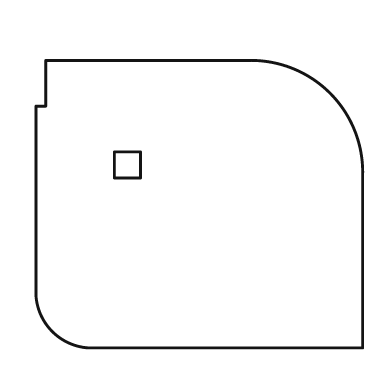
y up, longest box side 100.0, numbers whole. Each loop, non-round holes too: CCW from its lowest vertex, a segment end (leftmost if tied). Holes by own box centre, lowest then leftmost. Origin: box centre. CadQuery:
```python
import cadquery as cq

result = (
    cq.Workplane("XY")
    .moveTo(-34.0, -44.0)
    .lineTo(50.0, -44.0)
    .lineTo(50.0, 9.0)
    .threePointArc((40.0, 34.0), (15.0, 44.0))
    .lineTo(-47.0, 44.0)
    .lineTo(-47.0, 30.0)
    .lineTo(-50.0, 30.0)
    .lineTo(-50.0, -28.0)
    .threePointArc((-45.0, -39.0), (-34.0, -44.0))
    .close()
    .moveTo(-26.0, 8.0)
    .lineTo(-18.0, 8.0)
    .lineTo(-18.0, 16.0)
    .lineTo(-26.0, 16.0)
    .close()
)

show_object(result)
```